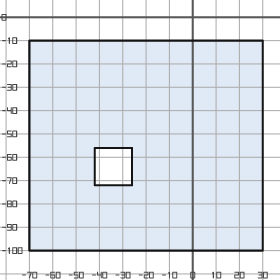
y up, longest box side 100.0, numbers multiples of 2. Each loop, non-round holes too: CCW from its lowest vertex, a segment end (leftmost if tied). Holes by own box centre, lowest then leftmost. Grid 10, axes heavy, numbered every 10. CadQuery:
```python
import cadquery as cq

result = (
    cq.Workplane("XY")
    .moveTo(-70.0, -100.0)
    .lineTo(30.0, -100.0)
    .lineTo(30.0, -10.0)
    .lineTo(-70.0, -10.0)
    .close()
    .moveTo(-42.0, -72.0)
    .lineTo(-26.0, -72.0)
    .lineTo(-26.0, -56.0)
    .lineTo(-42.0, -56.0)
    .close()
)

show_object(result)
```